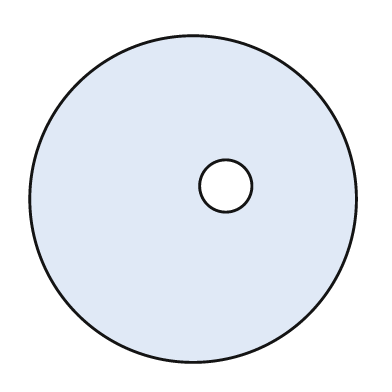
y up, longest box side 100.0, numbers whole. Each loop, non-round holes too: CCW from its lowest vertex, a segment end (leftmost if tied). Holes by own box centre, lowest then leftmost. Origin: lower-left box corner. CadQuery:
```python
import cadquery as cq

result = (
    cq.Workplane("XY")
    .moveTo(50.0, 50.0)
    .circle(50.0)
    .moveTo(60.0, 54.0)
    .circle(8.0)
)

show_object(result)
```